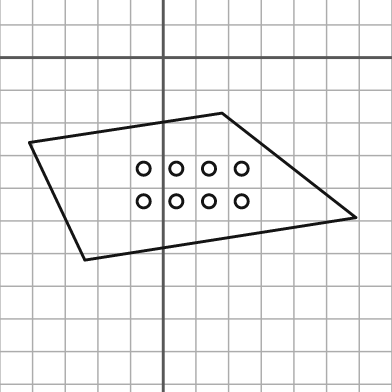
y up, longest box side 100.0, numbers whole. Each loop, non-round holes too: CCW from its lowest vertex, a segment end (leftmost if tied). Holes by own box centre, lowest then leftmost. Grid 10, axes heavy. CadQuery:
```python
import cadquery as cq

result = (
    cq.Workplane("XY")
    .moveTo(-24.0, -62.0)
    .lineTo(59.0, -49.0)
    .lineTo(18.0, -17.0)
    .lineTo(-41.0, -26.0)
    .close()
    .moveTo(-6.0, -44.0)
    .circle(2.0)
    .moveTo(4.0, -44.0)
    .circle(2.0)
    .moveTo(14.0, -44.0)
    .circle(2.0)
    .moveTo(24.0, -44.0)
    .circle(2.0)
    .moveTo(-6.0, -34.0)
    .circle(2.0)
    .moveTo(4.0, -34.0)
    .circle(2.0)
    .moveTo(14.0, -34.0)
    .circle(2.0)
    .moveTo(24.0, -34.0)
    .circle(2.0)
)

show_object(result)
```